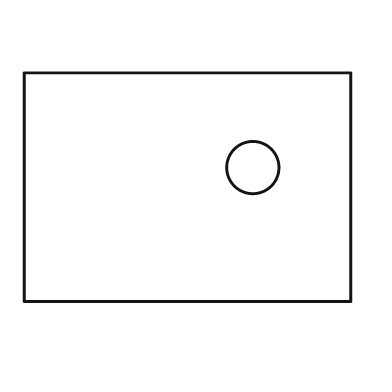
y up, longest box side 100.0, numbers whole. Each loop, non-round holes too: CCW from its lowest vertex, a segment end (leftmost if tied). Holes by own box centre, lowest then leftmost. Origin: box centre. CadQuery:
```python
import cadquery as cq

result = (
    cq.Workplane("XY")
    .moveTo(-50.0, -35.0)
    .lineTo(50.0, -35.0)
    .lineTo(50.0, 35.0)
    .lineTo(-50.0, 35.0)
    .close()
    .moveTo(20.0, 6.0)
    .circle(8.0)
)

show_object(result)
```